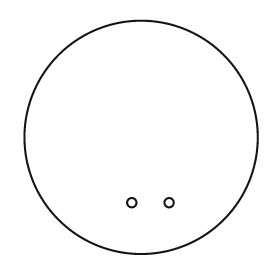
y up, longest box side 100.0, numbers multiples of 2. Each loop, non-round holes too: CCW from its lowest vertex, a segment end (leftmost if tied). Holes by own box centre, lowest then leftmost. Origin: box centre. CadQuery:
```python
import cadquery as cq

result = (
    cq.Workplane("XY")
    .moveTo(0.0, 0.0)
    .circle(50.0)
    .moveTo(-4.0, -28.0)
    .circle(2.0)
    .moveTo(12.0, -28.0)
    .circle(2.0)
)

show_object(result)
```